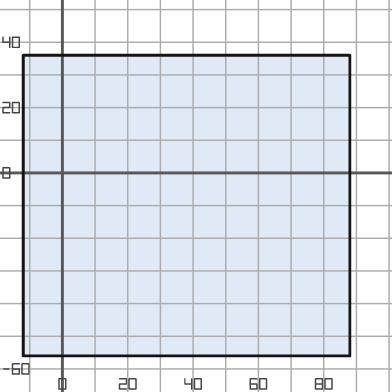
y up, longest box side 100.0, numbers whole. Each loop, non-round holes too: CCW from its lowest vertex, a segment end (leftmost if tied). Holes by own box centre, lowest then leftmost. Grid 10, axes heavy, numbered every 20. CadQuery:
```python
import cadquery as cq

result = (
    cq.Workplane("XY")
    .moveTo(-12.0, -56.0)
    .lineTo(88.0, -56.0)
    .lineTo(88.0, 36.0)
    .lineTo(-12.0, 36.0)
    .close()
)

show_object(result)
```